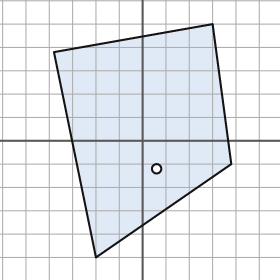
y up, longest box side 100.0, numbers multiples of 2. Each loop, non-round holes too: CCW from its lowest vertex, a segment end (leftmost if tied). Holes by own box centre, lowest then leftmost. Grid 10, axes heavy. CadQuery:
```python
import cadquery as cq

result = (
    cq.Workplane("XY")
    .moveTo(-20.0, -50.0)
    .lineTo(38.0, -10.0)
    .lineTo(30.0, 50.0)
    .lineTo(-38.0, 38.0)
    .close()
    .moveTo(6.0, -12.0)
    .circle(2.0)
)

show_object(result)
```